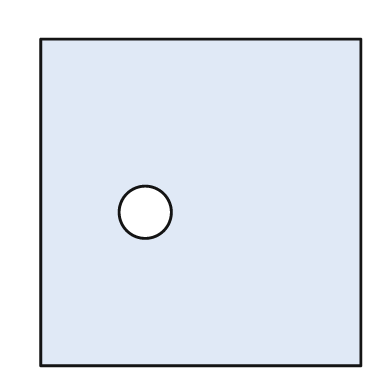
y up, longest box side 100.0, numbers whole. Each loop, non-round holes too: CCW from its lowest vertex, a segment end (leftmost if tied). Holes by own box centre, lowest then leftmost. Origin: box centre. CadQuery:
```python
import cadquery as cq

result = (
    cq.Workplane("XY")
    .moveTo(-49.0, -50.0)
    .lineTo(49.0, -50.0)
    .lineTo(49.0, 50.0)
    .lineTo(-49.0, 50.0)
    .close()
    .moveTo(-17.0, -3.0)
    .circle(8.0)
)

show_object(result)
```